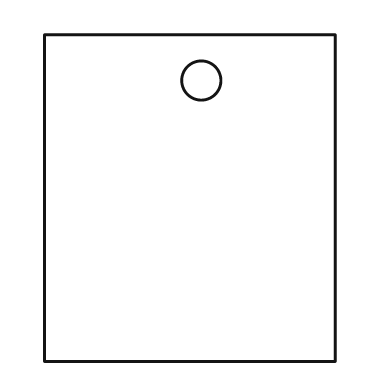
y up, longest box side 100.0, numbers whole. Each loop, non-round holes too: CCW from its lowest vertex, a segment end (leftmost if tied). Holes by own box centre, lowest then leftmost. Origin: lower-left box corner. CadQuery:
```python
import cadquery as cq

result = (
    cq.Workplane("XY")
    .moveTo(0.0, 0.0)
    .lineTo(89.0, 0.0)
    .lineTo(89.0, 100.0)
    .lineTo(0.0, 100.0)
    .close()
    .moveTo(48.0, 86.0)
    .circle(6.0)
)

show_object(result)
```